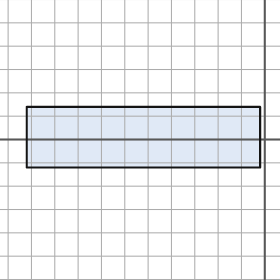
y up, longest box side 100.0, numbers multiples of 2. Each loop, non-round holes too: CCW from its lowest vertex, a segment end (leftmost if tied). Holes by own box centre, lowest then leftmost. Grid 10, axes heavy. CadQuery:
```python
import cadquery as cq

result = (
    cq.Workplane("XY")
    .moveTo(-102.0, -12.0)
    .lineTo(-2.0, -12.0)
    .lineTo(-2.0, 14.0)
    .lineTo(-102.0, 14.0)
    .close()
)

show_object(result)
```